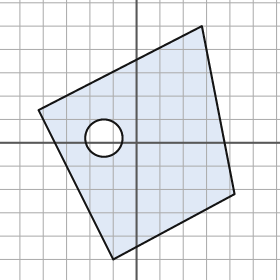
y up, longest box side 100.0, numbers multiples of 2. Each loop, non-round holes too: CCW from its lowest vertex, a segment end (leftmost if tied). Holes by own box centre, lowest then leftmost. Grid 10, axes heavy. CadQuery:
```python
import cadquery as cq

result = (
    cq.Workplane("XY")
    .moveTo(-10.0, -50.0)
    .lineTo(42.0, -22.0)
    .lineTo(28.0, 50.0)
    .lineTo(-42.0, 14.0)
    .close()
    .moveTo(-14.0, 2.0)
    .circle(8.0)
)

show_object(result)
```